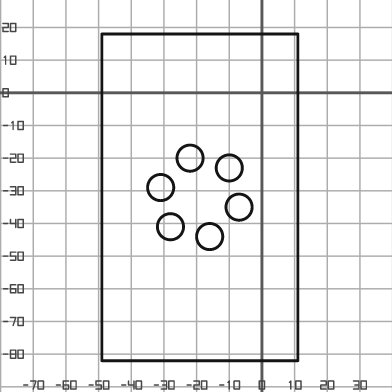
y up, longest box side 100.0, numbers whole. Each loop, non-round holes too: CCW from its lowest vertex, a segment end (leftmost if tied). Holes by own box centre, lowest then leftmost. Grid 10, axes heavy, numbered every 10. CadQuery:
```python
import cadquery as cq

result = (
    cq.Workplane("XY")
    .moveTo(-49.0, -82.0)
    .lineTo(11.0, -82.0)
    .lineTo(11.0, 18.0)
    .lineTo(-49.0, 18.0)
    .close()
    .moveTo(-16.0, -44.0)
    .circle(4.0)
    .moveTo(-28.0, -41.0)
    .circle(4.0)
    .moveTo(-7.0, -35.0)
    .circle(4.0)
    .moveTo(-31.0, -29.0)
    .circle(4.0)
    .moveTo(-10.0, -23.0)
    .circle(4.0)
    .moveTo(-22.0, -20.0)
    .circle(4.0)
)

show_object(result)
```